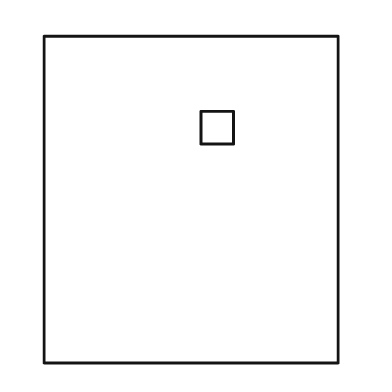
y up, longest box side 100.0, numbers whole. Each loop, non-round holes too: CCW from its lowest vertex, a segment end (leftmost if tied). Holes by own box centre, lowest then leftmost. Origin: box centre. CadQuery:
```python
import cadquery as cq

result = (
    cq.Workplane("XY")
    .moveTo(-45.0, -50.0)
    .lineTo(45.0, -50.0)
    .lineTo(45.0, 50.0)
    .lineTo(-45.0, 50.0)
    .close()
    .moveTo(3.0, 17.0)
    .lineTo(13.0, 17.0)
    .lineTo(13.0, 27.0)
    .lineTo(3.0, 27.0)
    .close()
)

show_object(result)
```